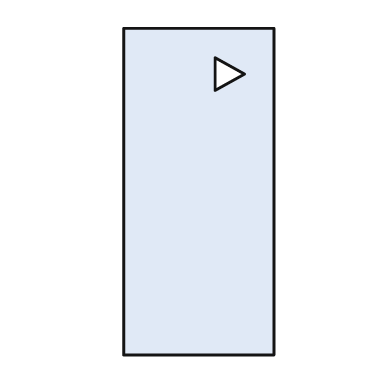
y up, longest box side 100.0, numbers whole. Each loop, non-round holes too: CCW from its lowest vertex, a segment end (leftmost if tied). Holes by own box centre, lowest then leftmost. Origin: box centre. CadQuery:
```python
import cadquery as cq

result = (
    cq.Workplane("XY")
    .moveTo(-23.0, -50.0)
    .lineTo(23.0, -50.0)
    .lineTo(23.0, 50.0)
    .lineTo(-23.0, 50.0)
    .close()
    .moveTo(5.0, 31.0)
    .lineTo(14.0, 36.0)
    .lineTo(5.0, 41.0)
    .close()
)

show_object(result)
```